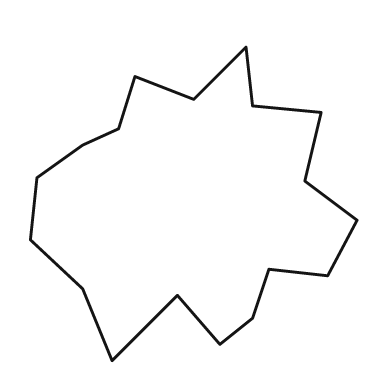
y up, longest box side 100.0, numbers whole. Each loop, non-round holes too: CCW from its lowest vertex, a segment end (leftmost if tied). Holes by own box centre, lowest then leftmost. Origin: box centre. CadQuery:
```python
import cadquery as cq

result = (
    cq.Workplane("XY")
    .moveTo(-25.0, -48.0)
    .lineTo(-5.0, -28.0)
    .lineTo(8.0, -43.0)
    .lineTo(18.0, -35.0)
    .lineTo(23.0, -20.0)
    .lineTo(41.0, -22.0)
    .lineTo(50.0, -5.0)
    .lineTo(34.0, 7.0)
    .lineTo(39.0, 28.0)
    .lineTo(18.0, 30.0)
    .lineTo(16.0, 48.0)
    .lineTo(0.0, 32.0)
    .lineTo(-18.0, 39.0)
    .lineTo(-23.0, 23.0)
    .lineTo(-34.0, 18.0)
    .lineTo(-48.0, 8.0)
    .lineTo(-50.0, -11.0)
    .lineTo(-34.0, -26.0)
    .close()
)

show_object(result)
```